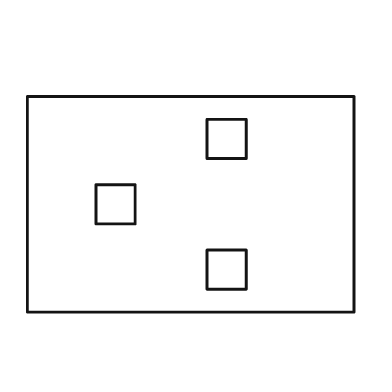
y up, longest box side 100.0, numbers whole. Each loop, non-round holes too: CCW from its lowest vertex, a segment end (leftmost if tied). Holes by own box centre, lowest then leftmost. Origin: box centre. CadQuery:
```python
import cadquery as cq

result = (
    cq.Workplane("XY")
    .moveTo(-50.0, -33.0)
    .lineTo(50.0, -33.0)
    .lineTo(50.0, 33.0)
    .lineTo(-50.0, 33.0)
    .close()
    .moveTo(5.0, -26.0)
    .lineTo(17.0, -26.0)
    .lineTo(17.0, -14.0)
    .lineTo(5.0, -14.0)
    .close()
    .moveTo(-29.0, -6.0)
    .lineTo(-17.0, -6.0)
    .lineTo(-17.0, 6.0)
    .lineTo(-29.0, 6.0)
    .close()
    .moveTo(5.0, 14.0)
    .lineTo(17.0, 14.0)
    .lineTo(17.0, 26.0)
    .lineTo(5.0, 26.0)
    .close()
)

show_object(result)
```